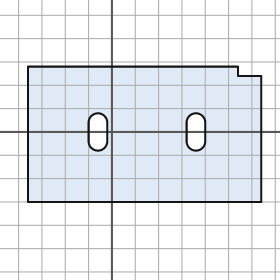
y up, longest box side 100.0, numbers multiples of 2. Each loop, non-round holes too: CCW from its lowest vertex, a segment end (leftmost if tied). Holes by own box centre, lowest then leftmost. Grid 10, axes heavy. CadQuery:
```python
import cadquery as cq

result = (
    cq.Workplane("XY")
    .moveTo(-36.0, -30.0)
    .lineTo(64.0, -30.0)
    .lineTo(64.0, 24.0)
    .lineTo(54.0, 24.0)
    .lineTo(54.0, 28.0)
    .lineTo(-36.0, 28.0)
    .close()
    .moveTo(-10.0, -4.0)
    .threePointArc((-6.0, -8.0), (-2.0, -4.0))
    .lineTo(-2.0, 4.0)
    .threePointArc((-6.0, 8.0), (-10.0, 4.0))
    .close()
    .moveTo(32.0, -4.0)
    .threePointArc((36.0, -8.0), (40.0, -4.0))
    .lineTo(40.0, 4.0)
    .threePointArc((36.0, 8.0), (32.0, 4.0))
    .close()
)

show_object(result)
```